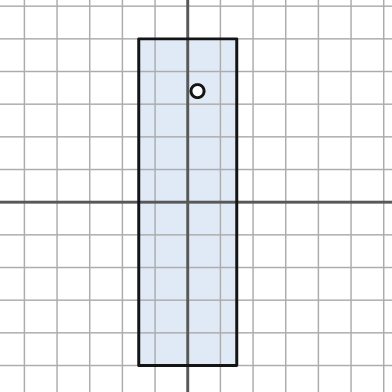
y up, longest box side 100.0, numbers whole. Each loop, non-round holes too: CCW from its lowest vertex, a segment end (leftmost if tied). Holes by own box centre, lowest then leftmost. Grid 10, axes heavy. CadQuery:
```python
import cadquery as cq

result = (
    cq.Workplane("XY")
    .moveTo(-15.0, -50.0)
    .lineTo(15.0, -50.0)
    .lineTo(15.0, 50.0)
    .lineTo(-15.0, 50.0)
    .close()
    .moveTo(3.0, 34.0)
    .circle(2.0)
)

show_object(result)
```